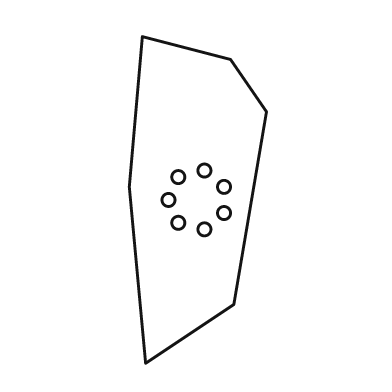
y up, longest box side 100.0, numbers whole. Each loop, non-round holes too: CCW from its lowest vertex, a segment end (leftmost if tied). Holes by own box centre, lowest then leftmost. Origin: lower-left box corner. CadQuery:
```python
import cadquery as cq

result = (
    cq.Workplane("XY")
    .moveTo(5.0, 0.0)
    .lineTo(32.0, 18.0)
    .lineTo(42.0, 77.0)
    .lineTo(31.0, 93.0)
    .lineTo(4.0, 100.0)
    .lineTo(0.0, 54.0)
    .close()
    .moveTo(23.0, 41.0)
    .circle(2.0)
    .moveTo(15.0, 43.0)
    .circle(2.0)
    .moveTo(29.0, 46.0)
    .circle(2.0)
    .moveTo(12.0, 50.0)
    .circle(2.0)
    .moveTo(29.0, 54.0)
    .circle(2.0)
    .moveTo(15.0, 57.0)
    .circle(2.0)
    .moveTo(23.0, 59.0)
    .circle(2.0)
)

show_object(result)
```